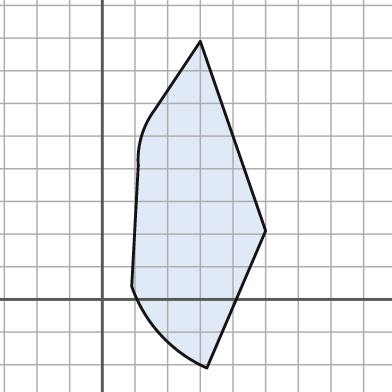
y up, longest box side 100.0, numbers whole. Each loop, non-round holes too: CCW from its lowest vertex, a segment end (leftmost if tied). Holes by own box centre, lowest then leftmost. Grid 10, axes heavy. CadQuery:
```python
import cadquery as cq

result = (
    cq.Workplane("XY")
    .moveTo(32.0, -21.0)
    .lineTo(50.0, 21.0)
    .lineTo(30.0, 79.0)
    .lineTo(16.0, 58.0)
    .threePointArc((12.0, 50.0), (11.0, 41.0))
    .lineTo(9.0, 4.0)
    .threePointArc((18.0, -11.0), (32.0, -21.0))
    .close()
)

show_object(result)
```